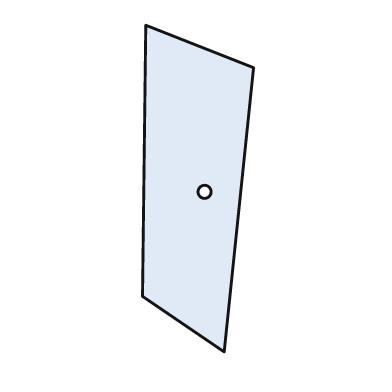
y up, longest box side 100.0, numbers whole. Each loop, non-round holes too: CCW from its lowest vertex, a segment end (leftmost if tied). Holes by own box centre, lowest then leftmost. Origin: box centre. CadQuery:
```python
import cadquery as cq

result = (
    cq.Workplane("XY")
    .moveTo(8.0, -50.0)
    .lineTo(17.0, 37.0)
    .lineTo(-16.0, 50.0)
    .lineTo(-17.0, -33.0)
    .close()
    .moveTo(2.0, -1.0)
    .circle(2.0)
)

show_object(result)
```